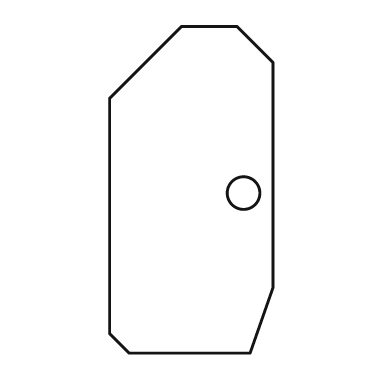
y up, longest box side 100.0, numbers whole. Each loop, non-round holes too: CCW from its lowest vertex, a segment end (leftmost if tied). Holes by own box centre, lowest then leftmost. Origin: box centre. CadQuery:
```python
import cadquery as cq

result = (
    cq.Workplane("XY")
    .moveTo(-19.0, -50.0)
    .lineTo(18.0, -50.0)
    .lineTo(25.0, -30.0)
    .lineTo(25.0, 39.0)
    .lineTo(14.0, 50.0)
    .lineTo(-3.0, 50.0)
    .lineTo(-25.0, 28.0)
    .lineTo(-25.0, -44.0)
    .close()
    .moveTo(16.0, -1.0)
    .circle(5.0)
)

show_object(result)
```